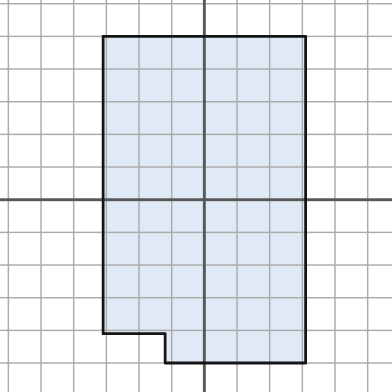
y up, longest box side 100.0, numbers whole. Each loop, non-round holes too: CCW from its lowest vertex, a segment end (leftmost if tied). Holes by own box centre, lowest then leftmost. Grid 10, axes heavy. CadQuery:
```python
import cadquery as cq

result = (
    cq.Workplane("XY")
    .moveTo(-12.0, -50.0)
    .lineTo(31.0, -50.0)
    .lineTo(31.0, 50.0)
    .lineTo(-31.0, 50.0)
    .lineTo(-31.0, -41.0)
    .lineTo(-12.0, -41.0)
    .close()
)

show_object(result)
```